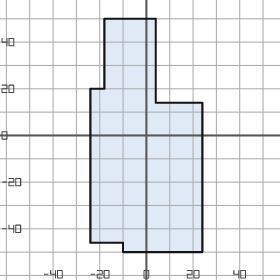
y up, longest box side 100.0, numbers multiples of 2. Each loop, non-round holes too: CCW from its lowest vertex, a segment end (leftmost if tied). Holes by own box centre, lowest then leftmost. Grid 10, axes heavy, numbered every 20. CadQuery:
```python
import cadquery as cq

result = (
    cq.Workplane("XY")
    .moveTo(-10.0, -50.0)
    .lineTo(24.0, -50.0)
    .lineTo(24.0, 14.0)
    .lineTo(4.0, 14.0)
    .lineTo(4.0, 50.0)
    .lineTo(-18.0, 50.0)
    .lineTo(-18.0, 20.0)
    .lineTo(-24.0, 20.0)
    .lineTo(-24.0, -46.0)
    .lineTo(-10.0, -46.0)
    .close()
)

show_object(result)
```